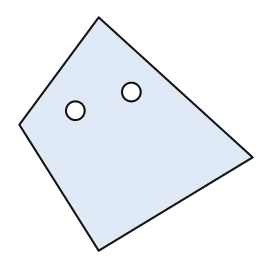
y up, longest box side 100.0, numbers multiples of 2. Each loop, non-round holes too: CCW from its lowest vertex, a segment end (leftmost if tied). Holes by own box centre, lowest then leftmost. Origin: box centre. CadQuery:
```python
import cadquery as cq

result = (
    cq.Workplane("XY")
    .moveTo(-16.0, -50.0)
    .lineTo(50.0, -10.0)
    .lineTo(-16.0, 50.0)
    .lineTo(-50.0, 4.0)
    .close()
    .moveTo(-26.0, 10.0)
    .circle(4.0)
    .moveTo(-2.0, 18.0)
    .circle(4.0)
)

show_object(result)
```